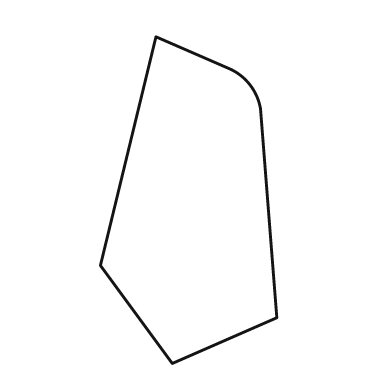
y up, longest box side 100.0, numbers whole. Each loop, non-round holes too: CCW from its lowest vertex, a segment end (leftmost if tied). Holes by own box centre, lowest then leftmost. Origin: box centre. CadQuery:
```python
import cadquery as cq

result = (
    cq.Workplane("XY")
    .moveTo(-5.0, -50.0)
    .lineTo(27.0, -36.0)
    .lineTo(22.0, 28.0)
    .threePointArc((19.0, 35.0), (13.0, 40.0))
    .lineTo(-10.0, 50.0)
    .lineTo(-27.0, -20.0)
    .close()
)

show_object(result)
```